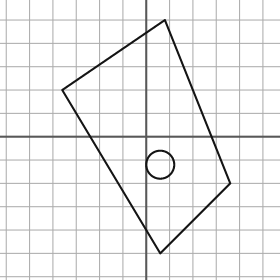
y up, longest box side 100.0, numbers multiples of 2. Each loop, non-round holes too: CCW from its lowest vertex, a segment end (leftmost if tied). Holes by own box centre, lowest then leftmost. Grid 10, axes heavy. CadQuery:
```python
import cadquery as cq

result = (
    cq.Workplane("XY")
    .moveTo(6.0, -50.0)
    .lineTo(36.0, -20.0)
    .lineTo(8.0, 50.0)
    .lineTo(-36.0, 20.0)
    .close()
    .moveTo(6.0, -12.0)
    .circle(6.0)
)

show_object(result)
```